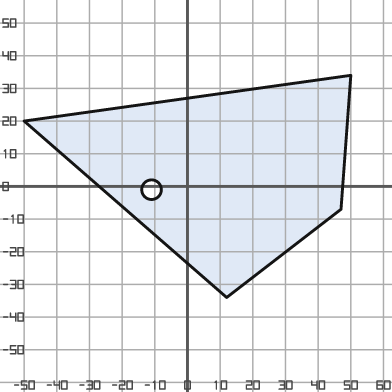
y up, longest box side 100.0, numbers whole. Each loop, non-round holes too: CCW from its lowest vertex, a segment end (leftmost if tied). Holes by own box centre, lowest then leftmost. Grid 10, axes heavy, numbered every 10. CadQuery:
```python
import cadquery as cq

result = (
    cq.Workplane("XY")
    .moveTo(12.0, -34.0)
    .lineTo(47.0, -7.0)
    .lineTo(50.0, 34.0)
    .lineTo(-50.0, 20.0)
    .close()
    .moveTo(-11.0, -1.0)
    .circle(3.0)
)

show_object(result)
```